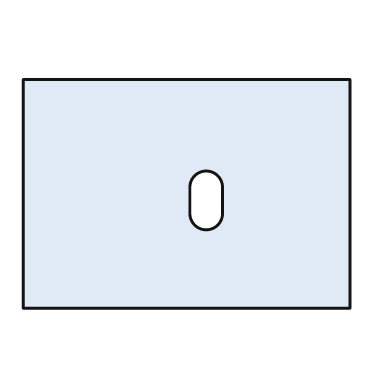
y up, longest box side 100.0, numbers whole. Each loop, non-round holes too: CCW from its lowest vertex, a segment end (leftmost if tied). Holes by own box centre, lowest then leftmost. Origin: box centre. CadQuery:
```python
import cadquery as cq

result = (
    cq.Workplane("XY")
    .moveTo(-50.0, -35.0)
    .lineTo(50.0, -35.0)
    .lineTo(50.0, 35.0)
    .lineTo(-50.0, 35.0)
    .close()
    .moveTo(1.0, -6.0)
    .threePointArc((6.0, -11.0), (11.0, -6.0))
    .lineTo(11.0, 2.0)
    .threePointArc((6.0, 7.0), (1.0, 2.0))
    .close()
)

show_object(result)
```